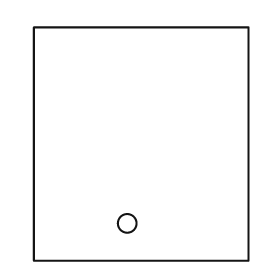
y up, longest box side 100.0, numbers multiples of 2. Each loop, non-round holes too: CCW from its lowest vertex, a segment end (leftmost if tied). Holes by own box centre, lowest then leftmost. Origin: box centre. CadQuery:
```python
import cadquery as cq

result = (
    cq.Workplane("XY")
    .moveTo(-46.0, -50.0)
    .lineTo(46.0, -50.0)
    .lineTo(46.0, 50.0)
    .lineTo(-46.0, 50.0)
    .close()
    .moveTo(-6.0, -34.0)
    .circle(4.0)
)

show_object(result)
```